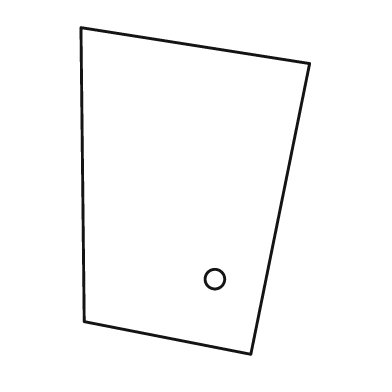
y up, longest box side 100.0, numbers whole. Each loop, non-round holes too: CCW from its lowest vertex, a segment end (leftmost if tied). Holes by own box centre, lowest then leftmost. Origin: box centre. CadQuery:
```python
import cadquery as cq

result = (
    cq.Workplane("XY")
    .moveTo(17.0, -50.0)
    .lineTo(35.0, 39.0)
    .lineTo(-35.0, 50.0)
    .lineTo(-34.0, -40.0)
    .close()
    .moveTo(6.0, -27.0)
    .circle(3.0)
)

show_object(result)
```